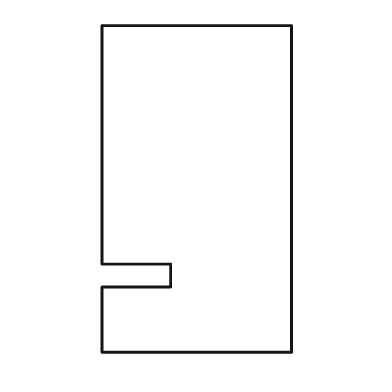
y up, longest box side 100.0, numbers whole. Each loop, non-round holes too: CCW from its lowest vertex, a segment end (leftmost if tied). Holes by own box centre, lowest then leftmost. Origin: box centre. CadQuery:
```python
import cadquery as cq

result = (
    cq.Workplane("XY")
    .moveTo(-29.0, -50.0)
    .lineTo(29.0, -50.0)
    .lineTo(29.0, 50.0)
    .lineTo(-29.0, 50.0)
    .lineTo(-29.0, -23.0)
    .lineTo(-8.0, -23.0)
    .lineTo(-8.0, -30.0)
    .lineTo(-29.0, -30.0)
    .close()
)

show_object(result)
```